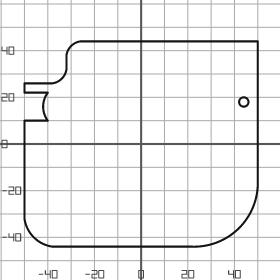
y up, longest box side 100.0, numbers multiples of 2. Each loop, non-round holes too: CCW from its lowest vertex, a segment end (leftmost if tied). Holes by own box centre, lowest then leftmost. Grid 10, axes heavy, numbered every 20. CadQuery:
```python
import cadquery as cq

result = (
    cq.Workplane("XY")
    .moveTo(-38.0, -44.0)
    .lineTo(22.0, -44.0)
    .threePointArc((42.0, -36.0), (50.0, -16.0))
    .lineTo(50.0, 44.0)
    .lineTo(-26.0, 44.0)
    .threePointArc((-30.0, 42.0), (-32.0, 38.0))
    .lineTo(-32.0, 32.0)
    .threePointArc((-34.0, 28.0), (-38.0, 26.0))
    .lineTo(-50.0, 26.0)
    .lineTo(-50.0, 22.0)
    .lineTo(-40.0, 22.0)
    .threePointArc((-42.0, 16.0), (-40.0, 10.0))
    .lineTo(-50.0, 10.0)
    .lineTo(-50.0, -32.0)
    .threePointArc((-46.0, -40.0), (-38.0, -44.0))
    .close()
    .moveTo(44.0, 18.0)
    .circle(2.0)
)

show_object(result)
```